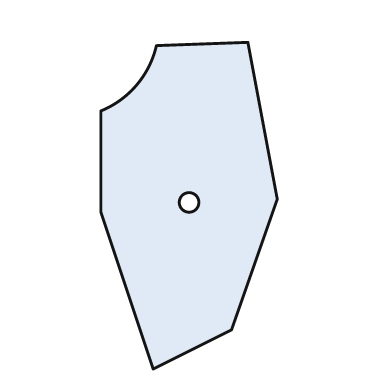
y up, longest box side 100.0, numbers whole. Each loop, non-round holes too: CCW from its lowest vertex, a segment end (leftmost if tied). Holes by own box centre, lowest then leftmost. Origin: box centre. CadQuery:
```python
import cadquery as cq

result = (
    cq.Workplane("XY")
    .moveTo(-11.0, -50.0)
    .lineTo(13.0, -38.0)
    .lineTo(27.0, 2.0)
    .lineTo(18.0, 50.0)
    .lineTo(-10.0, 49.0)
    .threePointArc((-16.0, 37.0), (-27.0, 29.0))
    .lineTo(-27.0, -2.0)
    .close()
    .moveTo(0.0, 1.0)
    .circle(3.0)
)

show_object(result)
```